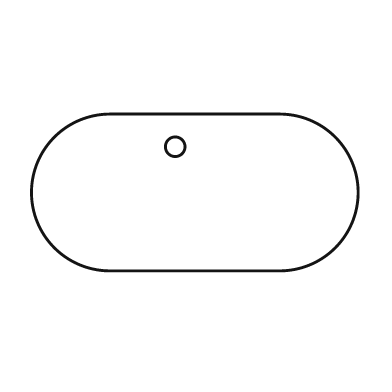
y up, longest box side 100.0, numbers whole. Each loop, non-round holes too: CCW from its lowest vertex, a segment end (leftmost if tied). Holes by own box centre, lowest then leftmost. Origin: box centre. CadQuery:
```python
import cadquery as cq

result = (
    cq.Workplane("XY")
    .moveTo(-26.0, -24.0)
    .lineTo(26.0, -24.0)
    .threePointArc((50.0, 0.0), (26.0, 24.0))
    .lineTo(-26.0, 24.0)
    .threePointArc((-50.0, 0.0), (-26.0, -24.0))
    .close()
    .moveTo(-6.0, 14.0)
    .circle(3.0)
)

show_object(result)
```